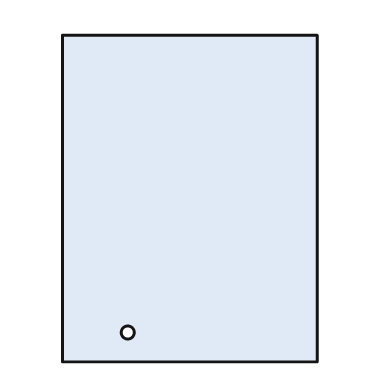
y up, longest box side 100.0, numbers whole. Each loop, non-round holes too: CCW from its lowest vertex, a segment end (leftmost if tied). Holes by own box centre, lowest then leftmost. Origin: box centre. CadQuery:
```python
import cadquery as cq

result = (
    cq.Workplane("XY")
    .moveTo(-39.0, -50.0)
    .lineTo(39.0, -50.0)
    .lineTo(39.0, 50.0)
    .lineTo(-39.0, 50.0)
    .close()
    .moveTo(-19.0, -41.0)
    .circle(2.0)
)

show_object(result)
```